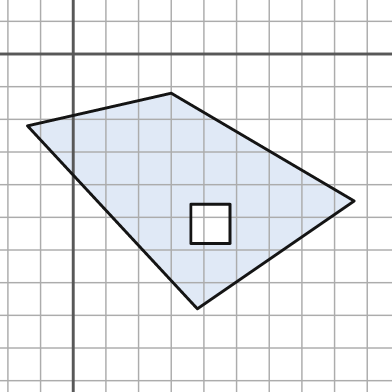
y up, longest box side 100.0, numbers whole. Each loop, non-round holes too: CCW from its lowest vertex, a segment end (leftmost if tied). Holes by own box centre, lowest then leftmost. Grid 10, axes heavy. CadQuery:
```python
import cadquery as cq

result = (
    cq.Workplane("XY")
    .moveTo(38.0, -78.0)
    .lineTo(86.0, -45.0)
    .lineTo(30.0, -12.0)
    .lineTo(-14.0, -22.0)
    .close()
    .moveTo(36.0, -58.0)
    .lineTo(48.0, -58.0)
    .lineTo(48.0, -46.0)
    .lineTo(36.0, -46.0)
    .close()
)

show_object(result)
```